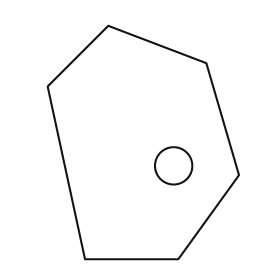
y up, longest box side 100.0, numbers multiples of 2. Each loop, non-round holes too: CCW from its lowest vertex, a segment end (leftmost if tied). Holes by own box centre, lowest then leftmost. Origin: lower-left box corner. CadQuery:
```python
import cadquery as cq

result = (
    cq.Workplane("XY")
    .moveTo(16.0, 0.0)
    .lineTo(56.0, 0.0)
    .lineTo(82.0, 36.0)
    .lineTo(68.0, 84.0)
    .lineTo(26.0, 100.0)
    .lineTo(0.0, 74.0)
    .close()
    .moveTo(54.0, 40.0)
    .circle(8.0)
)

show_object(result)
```